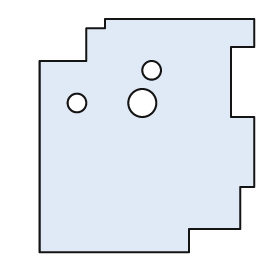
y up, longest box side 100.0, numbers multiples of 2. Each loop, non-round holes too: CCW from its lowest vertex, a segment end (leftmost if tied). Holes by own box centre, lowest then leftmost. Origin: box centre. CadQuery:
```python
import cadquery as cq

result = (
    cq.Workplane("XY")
    .moveTo(-46.0, -50.0)
    .lineTo(18.0, -50.0)
    .lineTo(18.0, -40.0)
    .lineTo(40.0, -40.0)
    .lineTo(40.0, -22.0)
    .lineTo(46.0, -22.0)
    .lineTo(46.0, 8.0)
    .lineTo(36.0, 8.0)
    .lineTo(36.0, 38.0)
    .lineTo(46.0, 38.0)
    .lineTo(46.0, 50.0)
    .lineTo(-18.0, 50.0)
    .lineTo(-18.0, 46.0)
    .lineTo(-26.0, 46.0)
    .lineTo(-26.0, 32.0)
    .lineTo(-46.0, 32.0)
    .close()
    .moveTo(-30.0, 14.0)
    .circle(4.0)
    .moveTo(-2.0, 14.0)
    .circle(6.0)
    .moveTo(2.0, 28.0)
    .circle(4.0)
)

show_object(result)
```